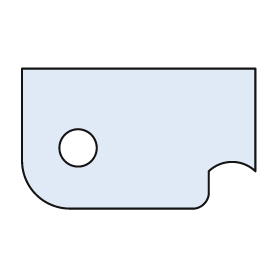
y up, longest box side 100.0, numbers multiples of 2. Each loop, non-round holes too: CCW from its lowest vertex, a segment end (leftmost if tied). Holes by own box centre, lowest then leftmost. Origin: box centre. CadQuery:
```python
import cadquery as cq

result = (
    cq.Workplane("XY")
    .moveTo(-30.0, -30.0)
    .lineTo(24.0, -30.0)
    .threePointArc((28.0, -28.0), (30.0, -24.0))
    .lineTo(30.0, -14.0)
    .threePointArc((40.0, -10.0), (50.0, -14.0))
    .lineTo(50.0, 30.0)
    .lineTo(-50.0, 30.0)
    .lineTo(-50.0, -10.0)
    .threePointArc((-44.0, -24.0), (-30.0, -30.0))
    .close()
    .moveTo(-26.0, -4.0)
    .circle(8.0)
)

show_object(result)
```